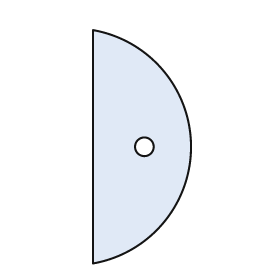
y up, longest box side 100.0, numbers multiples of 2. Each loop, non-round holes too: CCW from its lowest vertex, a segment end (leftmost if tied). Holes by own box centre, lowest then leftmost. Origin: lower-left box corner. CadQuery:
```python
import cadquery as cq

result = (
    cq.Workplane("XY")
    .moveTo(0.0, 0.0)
    .threePointArc((42.0, 50.0), (0.0, 100.0))
    .close()
    .moveTo(22.0, 50.0)
    .circle(4.0)
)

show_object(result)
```